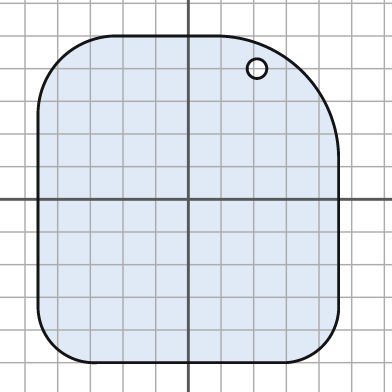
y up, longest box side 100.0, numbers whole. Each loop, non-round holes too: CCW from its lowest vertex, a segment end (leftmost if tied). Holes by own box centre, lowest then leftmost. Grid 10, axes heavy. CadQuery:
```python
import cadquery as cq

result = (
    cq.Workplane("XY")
    .moveTo(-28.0, -50.0)
    .lineTo(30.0, -50.0)
    .threePointArc((41.0, -45.0), (46.0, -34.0))
    .lineTo(46.0, 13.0)
    .threePointArc((35.0, 39.0), (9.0, 50.0))
    .lineTo(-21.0, 50.0)
    .threePointArc((-39.0, 43.0), (-46.0, 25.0))
    .lineTo(-46.0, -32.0)
    .threePointArc((-41.0, -45.0), (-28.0, -50.0))
    .close()
    .moveTo(21.0, 40.0)
    .circle(3.0)
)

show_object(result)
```